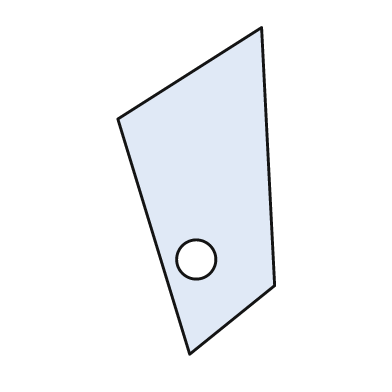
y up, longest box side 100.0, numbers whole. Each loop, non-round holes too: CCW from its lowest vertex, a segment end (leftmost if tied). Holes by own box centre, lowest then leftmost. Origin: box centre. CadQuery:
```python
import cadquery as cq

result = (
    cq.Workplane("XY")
    .moveTo(-2.0, -50.0)
    .lineTo(24.0, -29.0)
    .lineTo(20.0, 50.0)
    .lineTo(-24.0, 22.0)
    .close()
    .moveTo(0.0, -21.0)
    .circle(6.0)
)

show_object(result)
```